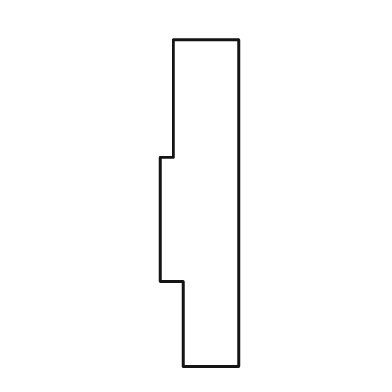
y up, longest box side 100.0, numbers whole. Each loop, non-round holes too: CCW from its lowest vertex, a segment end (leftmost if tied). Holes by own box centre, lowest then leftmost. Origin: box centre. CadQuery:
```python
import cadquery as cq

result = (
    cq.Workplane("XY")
    .moveTo(-5.0, -50.0)
    .lineTo(12.0, -50.0)
    .lineTo(12.0, 50.0)
    .lineTo(-8.0, 50.0)
    .lineTo(-8.0, 14.0)
    .lineTo(-12.0, 14.0)
    .lineTo(-12.0, -24.0)
    .lineTo(-5.0, -24.0)
    .close()
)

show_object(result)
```